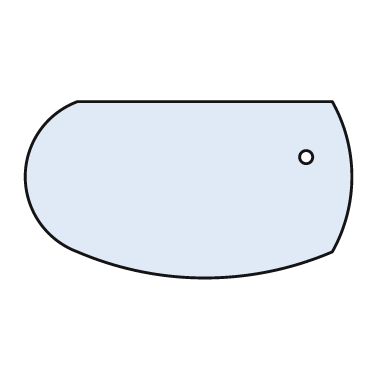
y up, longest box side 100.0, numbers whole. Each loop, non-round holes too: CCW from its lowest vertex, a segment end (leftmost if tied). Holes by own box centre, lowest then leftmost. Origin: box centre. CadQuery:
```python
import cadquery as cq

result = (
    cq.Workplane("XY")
    .moveTo(-34.0, -19.0)
    .threePointArc((5.0, -27.0), (44.0, -19.0))
    .threePointArc((50.0, 4.0), (44.0, 27.0))
    .lineTo(-34.0, 27.0)
    .threePointArc((-50.0, 4.0), (-34.0, -19.0))
    .close()
    .moveTo(36.0, 10.0)
    .circle(2.0)
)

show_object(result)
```